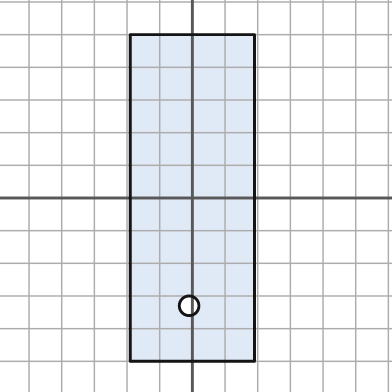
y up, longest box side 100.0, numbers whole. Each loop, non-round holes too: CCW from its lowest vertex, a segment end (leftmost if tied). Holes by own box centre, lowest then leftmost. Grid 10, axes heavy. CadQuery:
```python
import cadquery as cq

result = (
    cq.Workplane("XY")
    .moveTo(-19.0, -50.0)
    .lineTo(19.0, -50.0)
    .lineTo(19.0, 50.0)
    .lineTo(-19.0, 50.0)
    .close()
    .moveTo(-1.0, -33.0)
    .circle(3.0)
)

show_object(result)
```